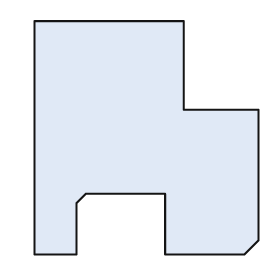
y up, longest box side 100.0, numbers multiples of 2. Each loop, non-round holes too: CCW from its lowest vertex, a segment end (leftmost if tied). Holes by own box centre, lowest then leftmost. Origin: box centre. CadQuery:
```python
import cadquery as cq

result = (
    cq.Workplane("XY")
    .moveTo(-48.0, -50.0)
    .lineTo(-30.0, -50.0)
    .lineTo(-30.0, -28.0)
    .lineTo(-26.0, -24.0)
    .lineTo(8.0, -24.0)
    .lineTo(8.0, -50.0)
    .lineTo(42.0, -50.0)
    .lineTo(48.0, -44.0)
    .lineTo(48.0, 12.0)
    .lineTo(16.0, 12.0)
    .lineTo(16.0, 50.0)
    .lineTo(-48.0, 50.0)
    .close()
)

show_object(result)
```